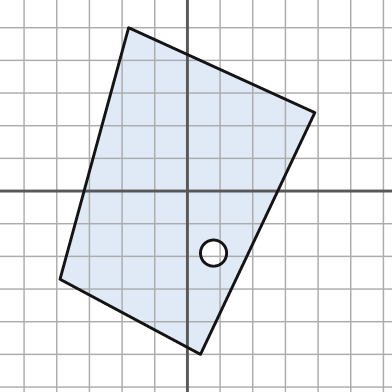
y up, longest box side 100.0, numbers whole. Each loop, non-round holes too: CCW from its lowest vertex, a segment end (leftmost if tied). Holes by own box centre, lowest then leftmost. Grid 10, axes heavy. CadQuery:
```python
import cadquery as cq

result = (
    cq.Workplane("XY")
    .moveTo(4.0, -50.0)
    .lineTo(39.0, 24.0)
    .lineTo(-18.0, 50.0)
    .lineTo(-39.0, -27.0)
    .close()
    .moveTo(8.0, -19.0)
    .circle(4.0)
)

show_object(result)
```